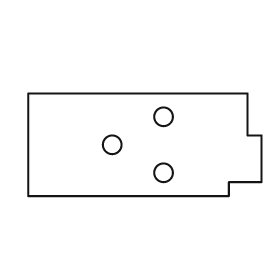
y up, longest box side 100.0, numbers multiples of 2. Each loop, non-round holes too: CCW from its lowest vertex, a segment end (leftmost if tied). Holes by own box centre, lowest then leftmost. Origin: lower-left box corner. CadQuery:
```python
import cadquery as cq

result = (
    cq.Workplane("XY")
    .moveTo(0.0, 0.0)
    .lineTo(86.0, 0.0)
    .lineTo(86.0, 6.0)
    .lineTo(100.0, 6.0)
    .lineTo(100.0, 26.0)
    .lineTo(94.0, 26.0)
    .lineTo(94.0, 44.0)
    .lineTo(0.0, 44.0)
    .close()
    .moveTo(58.0, 10.0)
    .circle(4.0)
    .moveTo(36.0, 22.0)
    .circle(4.0)
    .moveTo(58.0, 34.0)
    .circle(4.0)
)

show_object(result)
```